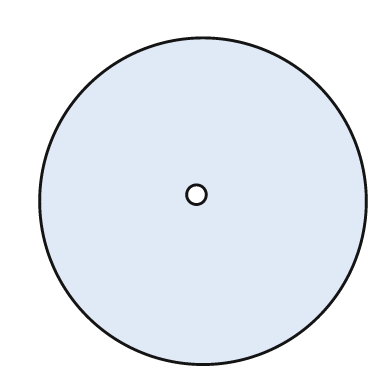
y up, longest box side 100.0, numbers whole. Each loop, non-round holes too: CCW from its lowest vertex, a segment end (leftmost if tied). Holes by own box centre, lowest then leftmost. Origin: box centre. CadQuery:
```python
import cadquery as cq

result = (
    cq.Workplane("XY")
    .moveTo(0.0, 0.0)
    .circle(50.0)
    .moveTo(-2.0, 2.0)
    .circle(3.0)
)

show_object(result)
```